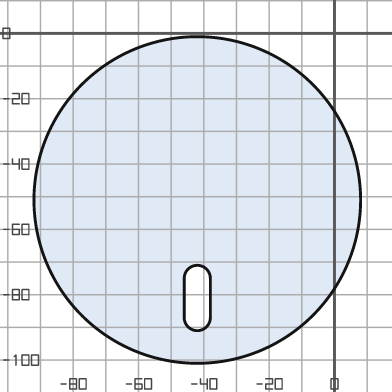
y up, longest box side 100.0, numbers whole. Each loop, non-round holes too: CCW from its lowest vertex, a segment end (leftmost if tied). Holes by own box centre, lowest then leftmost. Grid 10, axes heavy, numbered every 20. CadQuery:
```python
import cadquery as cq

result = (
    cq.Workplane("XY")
    .moveTo(-42.0, -51.0)
    .circle(50.0)
    .moveTo(-46.0, -87.0)
    .threePointArc((-42.0, -91.0), (-38.0, -87.0))
    .lineTo(-38.0, -75.0)
    .threePointArc((-42.0, -71.0), (-46.0, -75.0))
    .close()
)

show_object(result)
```